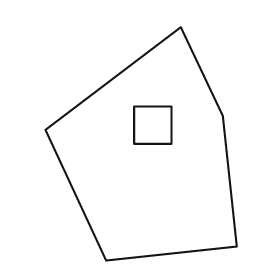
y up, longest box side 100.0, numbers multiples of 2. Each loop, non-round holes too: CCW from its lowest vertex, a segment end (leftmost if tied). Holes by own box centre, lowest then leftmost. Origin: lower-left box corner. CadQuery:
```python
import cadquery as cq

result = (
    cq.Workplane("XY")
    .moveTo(26.0, 0.0)
    .lineTo(82.0, 6.0)
    .lineTo(76.0, 62.0)
    .lineTo(58.0, 100.0)
    .lineTo(0.0, 56.0)
    .close()
    .moveTo(38.0, 50.0)
    .lineTo(54.0, 50.0)
    .lineTo(54.0, 66.0)
    .lineTo(38.0, 66.0)
    .close()
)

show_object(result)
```